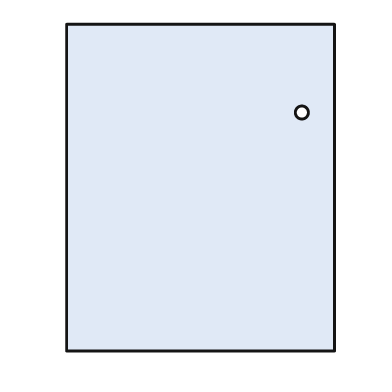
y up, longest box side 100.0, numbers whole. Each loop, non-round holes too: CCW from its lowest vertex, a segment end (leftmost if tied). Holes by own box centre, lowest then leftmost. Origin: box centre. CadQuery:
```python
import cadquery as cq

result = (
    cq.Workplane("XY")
    .moveTo(-41.0, -50.0)
    .lineTo(41.0, -50.0)
    .lineTo(41.0, 50.0)
    .lineTo(-41.0, 50.0)
    .close()
    .moveTo(31.0, 23.0)
    .circle(2.0)
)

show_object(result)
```